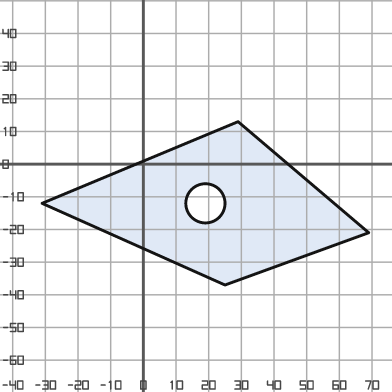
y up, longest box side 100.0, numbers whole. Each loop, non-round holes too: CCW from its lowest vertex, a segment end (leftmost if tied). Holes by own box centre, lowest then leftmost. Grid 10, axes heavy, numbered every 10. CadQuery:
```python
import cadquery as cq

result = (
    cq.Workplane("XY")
    .moveTo(25.0, -37.0)
    .lineTo(69.0, -21.0)
    .lineTo(29.0, 13.0)
    .lineTo(-31.0, -12.0)
    .close()
    .moveTo(19.0, -12.0)
    .circle(6.0)
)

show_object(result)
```